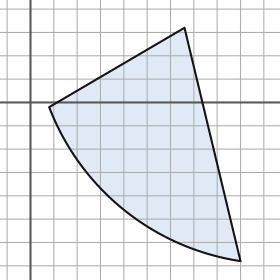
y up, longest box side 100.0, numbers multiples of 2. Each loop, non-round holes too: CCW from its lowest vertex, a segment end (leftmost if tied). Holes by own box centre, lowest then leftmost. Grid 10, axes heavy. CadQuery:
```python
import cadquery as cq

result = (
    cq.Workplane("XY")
    .moveTo(90.0, -68.0)
    .lineTo(66.0, 32.0)
    .lineTo(8.0, -2.0)
    .threePointArc((40.0, -46.0), (90.0, -68.0))
    .close()
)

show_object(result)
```